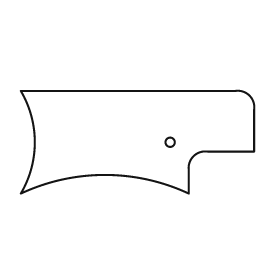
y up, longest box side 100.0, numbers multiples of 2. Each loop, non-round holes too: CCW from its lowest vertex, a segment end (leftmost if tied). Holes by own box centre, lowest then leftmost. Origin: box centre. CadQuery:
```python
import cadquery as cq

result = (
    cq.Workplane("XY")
    .moveTo(-50.0, -22.0)
    .threePointArc((-14.0, -14.0), (22.0, -22.0))
    .lineTo(22.0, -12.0)
    .threePointArc((24.0, -6.0), (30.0, -4.0))
    .lineTo(50.0, -4.0)
    .lineTo(50.0, 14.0)
    .threePointArc((48.0, 20.0), (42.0, 22.0))
    .lineTo(-50.0, 22.0)
    .threePointArc((-44.0, 0.0), (-50.0, -22.0))
    .close()
    .moveTo(14.0, 0.0)
    .circle(2.0)
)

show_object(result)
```